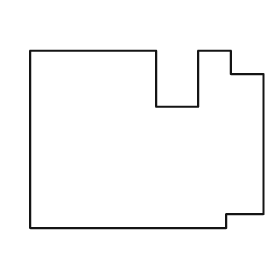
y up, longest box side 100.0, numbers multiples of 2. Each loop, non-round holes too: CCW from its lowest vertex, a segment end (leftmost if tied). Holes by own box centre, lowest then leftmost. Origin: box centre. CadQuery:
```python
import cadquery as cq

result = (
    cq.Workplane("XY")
    .moveTo(-50.0, -38.0)
    .lineTo(34.0, -38.0)
    .lineTo(34.0, -32.0)
    .lineTo(50.0, -32.0)
    .lineTo(50.0, 28.0)
    .lineTo(36.0, 28.0)
    .lineTo(36.0, 38.0)
    .lineTo(22.0, 38.0)
    .lineTo(22.0, 14.0)
    .lineTo(4.0, 14.0)
    .lineTo(4.0, 38.0)
    .lineTo(-50.0, 38.0)
    .close()
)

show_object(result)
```